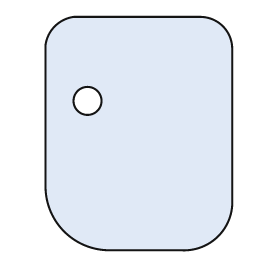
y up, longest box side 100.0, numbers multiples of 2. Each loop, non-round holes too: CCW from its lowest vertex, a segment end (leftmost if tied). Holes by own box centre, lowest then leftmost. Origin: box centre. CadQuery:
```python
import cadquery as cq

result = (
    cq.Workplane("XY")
    .moveTo(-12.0, -50.0)
    .lineTo(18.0, -50.0)
    .threePointArc((34.0, -44.0), (40.0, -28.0))
    .lineTo(40.0, 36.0)
    .threePointArc((36.0, 46.0), (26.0, 50.0))
    .lineTo(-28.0, 50.0)
    .threePointArc((-36.0, 46.0), (-40.0, 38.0))
    .lineTo(-40.0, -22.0)
    .threePointArc((-32.0, -42.0), (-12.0, -50.0))
    .close()
    .moveTo(-22.0, 14.0)
    .circle(6.0)
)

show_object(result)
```